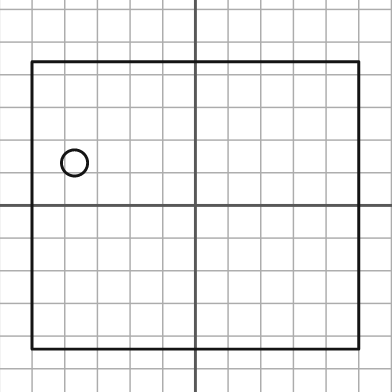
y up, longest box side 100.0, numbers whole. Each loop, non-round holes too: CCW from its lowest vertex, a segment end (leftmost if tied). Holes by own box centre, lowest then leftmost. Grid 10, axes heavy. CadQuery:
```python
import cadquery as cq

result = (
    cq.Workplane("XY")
    .moveTo(-50.0, -44.0)
    .lineTo(50.0, -44.0)
    .lineTo(50.0, 44.0)
    .lineTo(-50.0, 44.0)
    .close()
    .moveTo(-37.0, 13.0)
    .circle(4.0)
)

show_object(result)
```